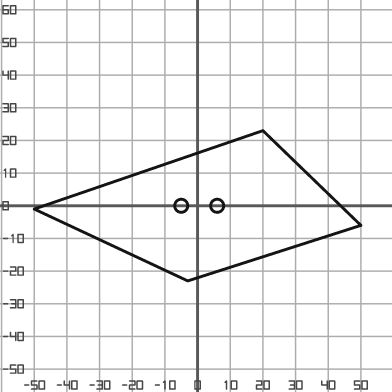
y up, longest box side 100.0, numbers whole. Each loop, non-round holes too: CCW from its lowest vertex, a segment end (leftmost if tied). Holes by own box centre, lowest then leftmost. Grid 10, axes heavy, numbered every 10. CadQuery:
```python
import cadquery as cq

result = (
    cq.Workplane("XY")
    .moveTo(-3.0, -23.0)
    .lineTo(50.0, -6.0)
    .lineTo(20.0, 23.0)
    .lineTo(-50.0, -1.0)
    .close()
    .moveTo(-5.0, 0.0)
    .circle(2.0)
    .moveTo(6.0, 0.0)
    .circle(2.0)
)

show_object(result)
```